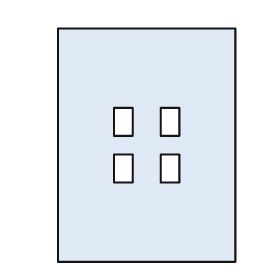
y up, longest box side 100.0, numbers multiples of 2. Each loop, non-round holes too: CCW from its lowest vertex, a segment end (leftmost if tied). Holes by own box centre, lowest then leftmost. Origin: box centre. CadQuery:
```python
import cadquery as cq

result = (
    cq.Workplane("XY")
    .moveTo(-38.0, -50.0)
    .lineTo(38.0, -50.0)
    .lineTo(38.0, 50.0)
    .lineTo(-38.0, 50.0)
    .close()
    .moveTo(-14.0, -16.0)
    .lineTo(-6.0, -16.0)
    .lineTo(-6.0, -4.0)
    .lineTo(-14.0, -4.0)
    .close()
    .moveTo(6.0, -16.0)
    .lineTo(14.0, -16.0)
    .lineTo(14.0, -4.0)
    .lineTo(6.0, -4.0)
    .close()
    .moveTo(-14.0, 4.0)
    .lineTo(-6.0, 4.0)
    .lineTo(-6.0, 16.0)
    .lineTo(-14.0, 16.0)
    .close()
    .moveTo(6.0, 4.0)
    .lineTo(14.0, 4.0)
    .lineTo(14.0, 16.0)
    .lineTo(6.0, 16.0)
    .close()
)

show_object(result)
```